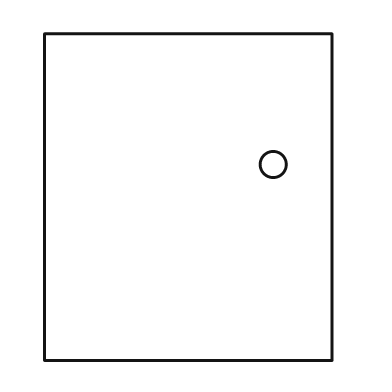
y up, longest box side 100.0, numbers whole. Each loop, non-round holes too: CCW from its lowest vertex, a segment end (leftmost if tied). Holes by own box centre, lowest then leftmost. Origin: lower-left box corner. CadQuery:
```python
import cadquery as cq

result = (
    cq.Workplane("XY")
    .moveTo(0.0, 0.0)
    .lineTo(88.0, 0.0)
    .lineTo(88.0, 100.0)
    .lineTo(0.0, 100.0)
    .close()
    .moveTo(70.0, 60.0)
    .circle(4.0)
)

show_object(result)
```